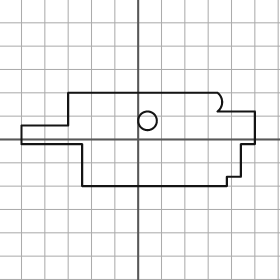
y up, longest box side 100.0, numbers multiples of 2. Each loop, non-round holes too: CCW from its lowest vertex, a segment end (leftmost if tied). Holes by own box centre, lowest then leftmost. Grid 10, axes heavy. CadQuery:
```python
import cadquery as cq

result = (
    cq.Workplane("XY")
    .moveTo(-24.0, -20.0)
    .lineTo(38.0, -20.0)
    .lineTo(38.0, -16.0)
    .lineTo(44.0, -16.0)
    .lineTo(44.0, -2.0)
    .lineTo(50.0, -2.0)
    .lineTo(50.0, 12.0)
    .lineTo(34.0, 12.0)
    .threePointArc((36.0, 16.0), (34.0, 20.0))
    .lineTo(-30.0, 20.0)
    .lineTo(-30.0, 6.0)
    .lineTo(-50.0, 6.0)
    .lineTo(-50.0, -2.0)
    .lineTo(-24.0, -2.0)
    .close()
    .moveTo(4.0, 8.0)
    .circle(4.0)
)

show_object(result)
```